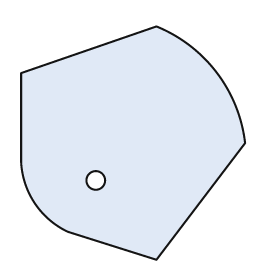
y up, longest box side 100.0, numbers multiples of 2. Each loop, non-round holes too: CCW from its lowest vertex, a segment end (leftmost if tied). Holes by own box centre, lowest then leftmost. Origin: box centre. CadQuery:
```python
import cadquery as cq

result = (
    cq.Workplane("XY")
    .moveTo(10.0, -50.0)
    .lineTo(48.0, 0.0)
    .threePointArc((36.0, 30.0), (10.0, 50.0))
    .lineTo(-48.0, 30.0)
    .lineTo(-48.0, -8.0)
    .threePointArc((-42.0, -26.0), (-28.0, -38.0))
    .close()
    .moveTo(-16.0, -16.0)
    .circle(4.0)
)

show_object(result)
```